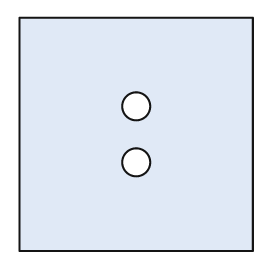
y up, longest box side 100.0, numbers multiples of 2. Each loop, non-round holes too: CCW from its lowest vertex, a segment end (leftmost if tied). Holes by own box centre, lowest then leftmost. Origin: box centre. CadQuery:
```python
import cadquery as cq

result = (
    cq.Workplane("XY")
    .moveTo(-50.0, -50.0)
    .lineTo(50.0, -50.0)
    .lineTo(50.0, 50.0)
    .lineTo(-50.0, 50.0)
    .close()
    .moveTo(0.0, -12.0)
    .circle(6.0)
    .moveTo(0.0, 12.0)
    .circle(6.0)
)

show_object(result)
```